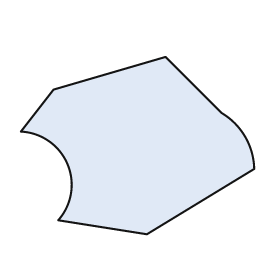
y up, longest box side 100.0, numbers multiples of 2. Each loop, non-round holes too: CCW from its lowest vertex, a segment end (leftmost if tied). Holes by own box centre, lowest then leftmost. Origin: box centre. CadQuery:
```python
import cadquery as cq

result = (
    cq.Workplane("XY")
    .moveTo(4.0, -38.0)
    .lineTo(50.0, -10.0)
    .threePointArc((46.0, 4.0), (36.0, 14.0))
    .lineTo(12.0, 38.0)
    .lineTo(-36.0, 24.0)
    .lineTo(-50.0, 6.0)
    .threePointArc((-30.0, -8.0), (-34.0, -32.0))
    .close()
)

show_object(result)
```